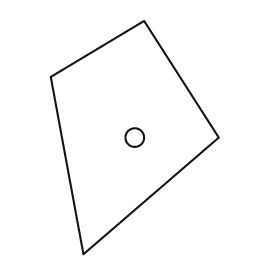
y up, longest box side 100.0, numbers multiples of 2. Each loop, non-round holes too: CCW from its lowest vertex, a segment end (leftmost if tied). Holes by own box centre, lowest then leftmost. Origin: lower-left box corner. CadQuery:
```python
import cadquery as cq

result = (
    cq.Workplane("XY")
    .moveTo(14.0, 0.0)
    .lineTo(72.0, 50.0)
    .lineTo(40.0, 100.0)
    .lineTo(0.0, 76.0)
    .close()
    .moveTo(36.0, 50.0)
    .circle(4.0)
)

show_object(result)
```